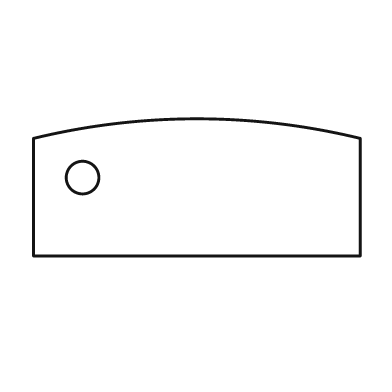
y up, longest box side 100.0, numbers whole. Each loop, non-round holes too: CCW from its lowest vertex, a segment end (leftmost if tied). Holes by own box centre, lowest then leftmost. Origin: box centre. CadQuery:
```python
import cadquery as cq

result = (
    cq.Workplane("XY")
    .moveTo(-50.0, -21.0)
    .lineTo(50.0, -21.0)
    .lineTo(50.0, 15.0)
    .threePointArc((0.0, 21.0), (-50.0, 15.0))
    .close()
    .moveTo(-35.0, 3.0)
    .circle(5.0)
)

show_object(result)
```